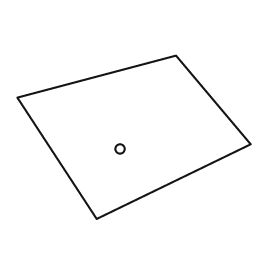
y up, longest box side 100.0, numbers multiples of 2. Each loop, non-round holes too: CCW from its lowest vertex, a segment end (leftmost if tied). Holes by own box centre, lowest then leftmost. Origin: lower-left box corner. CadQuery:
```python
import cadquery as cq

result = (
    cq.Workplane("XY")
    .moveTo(34.0, 0.0)
    .lineTo(100.0, 32.0)
    .lineTo(68.0, 70.0)
    .lineTo(0.0, 52.0)
    .close()
    .moveTo(44.0, 30.0)
    .circle(2.0)
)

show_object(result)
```